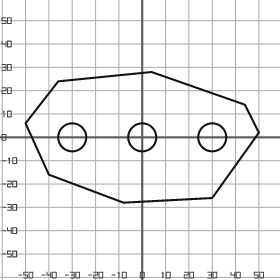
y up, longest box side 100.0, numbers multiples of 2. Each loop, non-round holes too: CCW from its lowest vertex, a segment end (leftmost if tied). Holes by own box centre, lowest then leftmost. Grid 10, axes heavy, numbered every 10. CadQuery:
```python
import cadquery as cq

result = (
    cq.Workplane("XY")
    .moveTo(-8.0, -28.0)
    .lineTo(30.0, -26.0)
    .lineTo(50.0, 2.0)
    .lineTo(44.0, 14.0)
    .lineTo(4.0, 28.0)
    .lineTo(-36.0, 24.0)
    .lineTo(-50.0, 6.0)
    .lineTo(-40.0, -16.0)
    .close()
    .moveTo(-30.0, 0.0)
    .circle(6.0)
    .moveTo(0.0, 0.0)
    .circle(6.0)
    .moveTo(30.0, 0.0)
    .circle(6.0)
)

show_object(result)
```